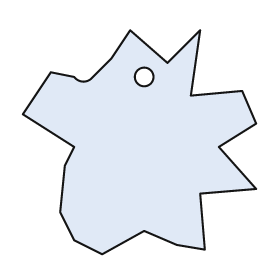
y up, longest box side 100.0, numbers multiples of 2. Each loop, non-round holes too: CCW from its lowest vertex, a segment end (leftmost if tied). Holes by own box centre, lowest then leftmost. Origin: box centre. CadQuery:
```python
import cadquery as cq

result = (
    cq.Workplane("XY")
    .moveTo(-16.0, -48.0)
    .lineTo(2.0, -38.0)
    .lineTo(16.0, -44.0)
    .lineTo(28.0, -46.0)
    .lineTo(26.0, -22.0)
    .lineTo(50.0, -20.0)
    .lineTo(34.0, -2.0)
    .lineTo(50.0, 8.0)
    .lineTo(44.0, 22.0)
    .lineTo(22.0, 20.0)
    .lineTo(26.0, 48.0)
    .lineTo(12.0, 34.0)
    .lineTo(-4.0, 48.0)
    .lineTo(-12.0, 36.0)
    .lineTo(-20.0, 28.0)
    .threePointArc((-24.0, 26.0), (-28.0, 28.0))
    .lineTo(-38.0, 30.0)
    .lineTo(-50.0, 12.0)
    .lineTo(-28.0, -2.0)
    .lineTo(-32.0, -10.0)
    .lineTo(-34.0, -30.0)
    .lineTo(-28.0, -42.0)
    .close()
    .moveTo(2.0, 28.0)
    .circle(4.0)
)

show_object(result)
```